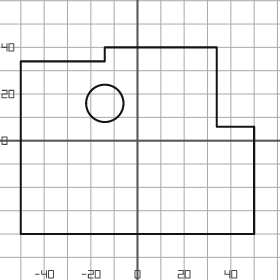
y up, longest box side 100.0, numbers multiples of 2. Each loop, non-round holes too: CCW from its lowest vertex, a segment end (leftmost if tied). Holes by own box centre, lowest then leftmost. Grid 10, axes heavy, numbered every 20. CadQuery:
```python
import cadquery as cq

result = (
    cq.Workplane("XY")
    .moveTo(-50.0, -40.0)
    .lineTo(50.0, -40.0)
    .lineTo(50.0, 6.0)
    .lineTo(34.0, 6.0)
    .lineTo(34.0, 40.0)
    .lineTo(-14.0, 40.0)
    .lineTo(-14.0, 34.0)
    .lineTo(-50.0, 34.0)
    .close()
    .moveTo(-14.0, 16.0)
    .circle(8.0)
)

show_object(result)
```